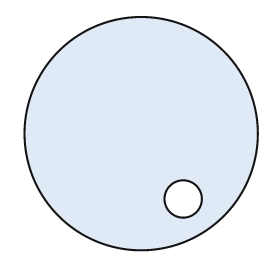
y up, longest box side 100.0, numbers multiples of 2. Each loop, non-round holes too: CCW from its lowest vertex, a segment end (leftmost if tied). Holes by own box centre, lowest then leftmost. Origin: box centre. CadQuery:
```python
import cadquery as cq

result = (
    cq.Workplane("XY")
    .moveTo(0.0, 0.0)
    .circle(50.0)
    .moveTo(18.0, -28.0)
    .circle(8.0)
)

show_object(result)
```